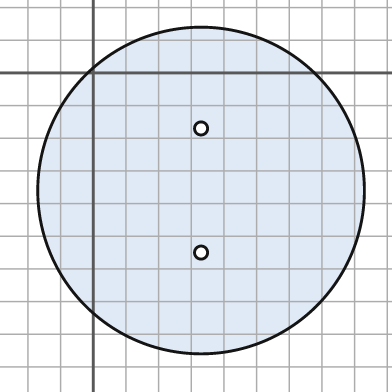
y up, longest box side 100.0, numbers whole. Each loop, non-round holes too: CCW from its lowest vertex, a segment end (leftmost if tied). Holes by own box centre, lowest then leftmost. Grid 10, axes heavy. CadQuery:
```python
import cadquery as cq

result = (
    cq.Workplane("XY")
    .moveTo(33.0, -36.0)
    .circle(50.0)
    .moveTo(33.0, -55.0)
    .circle(2.0)
    .moveTo(33.0, -17.0)
    .circle(2.0)
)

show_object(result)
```